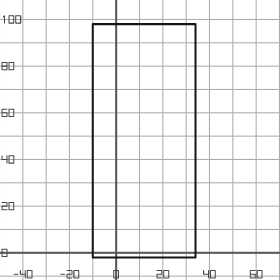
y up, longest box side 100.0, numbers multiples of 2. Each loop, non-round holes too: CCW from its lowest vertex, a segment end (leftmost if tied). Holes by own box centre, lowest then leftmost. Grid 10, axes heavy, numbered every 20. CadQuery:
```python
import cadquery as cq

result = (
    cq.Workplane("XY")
    .moveTo(-10.0, -2.0)
    .lineTo(34.0, -2.0)
    .lineTo(34.0, 98.0)
    .lineTo(-10.0, 98.0)
    .close()
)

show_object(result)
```